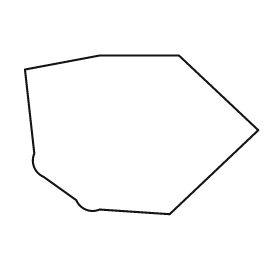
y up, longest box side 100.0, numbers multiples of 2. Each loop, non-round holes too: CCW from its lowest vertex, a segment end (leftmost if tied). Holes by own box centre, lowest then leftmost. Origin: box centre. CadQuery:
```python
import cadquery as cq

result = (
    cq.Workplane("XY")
    .moveTo(12.0, -34.0)
    .lineTo(50.0, 2.0)
    .lineTo(16.0, 34.0)
    .lineTo(-18.0, 34.0)
    .lineTo(-50.0, 28.0)
    .lineTo(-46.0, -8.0)
    .threePointArc((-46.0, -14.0), (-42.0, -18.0))
    .lineTo(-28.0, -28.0)
    .threePointArc((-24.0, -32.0), (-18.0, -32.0))
    .close()
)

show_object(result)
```